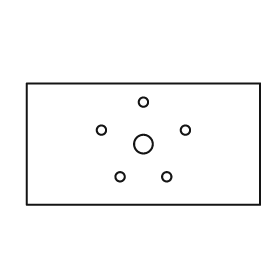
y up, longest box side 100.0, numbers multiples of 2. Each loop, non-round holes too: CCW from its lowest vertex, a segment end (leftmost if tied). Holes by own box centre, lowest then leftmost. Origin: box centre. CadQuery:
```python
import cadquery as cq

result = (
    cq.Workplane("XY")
    .moveTo(-50.0, -26.0)
    .lineTo(50.0, -26.0)
    .lineTo(50.0, 26.0)
    .lineTo(-50.0, 26.0)
    .close()
    .moveTo(-10.0, -14.0)
    .circle(2.0)
    .moveTo(10.0, -14.0)
    .circle(2.0)
    .moveTo(0.0, 0.0)
    .circle(4.0)
    .moveTo(-18.0, 6.0)
    .circle(2.0)
    .moveTo(18.0, 6.0)
    .circle(2.0)
    .moveTo(0.0, 18.0)
    .circle(2.0)
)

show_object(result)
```